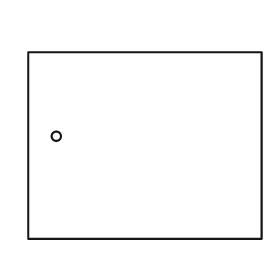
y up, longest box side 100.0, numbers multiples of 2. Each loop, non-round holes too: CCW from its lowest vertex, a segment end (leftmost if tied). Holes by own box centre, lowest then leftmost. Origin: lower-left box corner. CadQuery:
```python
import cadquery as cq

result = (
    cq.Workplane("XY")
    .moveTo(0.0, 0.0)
    .lineTo(100.0, 0.0)
    .lineTo(100.0, 80.0)
    .lineTo(0.0, 80.0)
    .close()
    .moveTo(12.0, 44.0)
    .circle(2.0)
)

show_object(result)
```